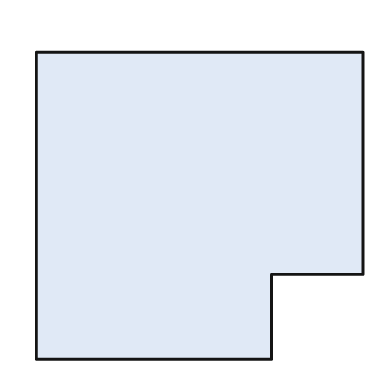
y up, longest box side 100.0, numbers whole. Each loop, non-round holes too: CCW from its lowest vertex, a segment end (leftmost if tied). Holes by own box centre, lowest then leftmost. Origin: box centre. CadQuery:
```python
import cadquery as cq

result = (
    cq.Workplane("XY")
    .moveTo(-50.0, -47.0)
    .lineTo(22.0, -47.0)
    .lineTo(22.0, -21.0)
    .lineTo(50.0, -21.0)
    .lineTo(50.0, 47.0)
    .lineTo(-50.0, 47.0)
    .close()
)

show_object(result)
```